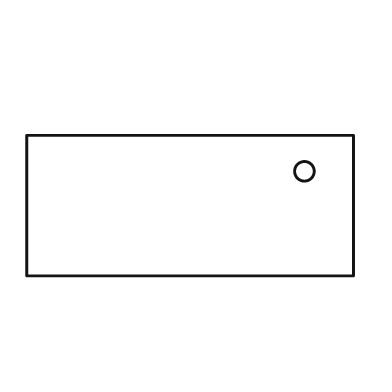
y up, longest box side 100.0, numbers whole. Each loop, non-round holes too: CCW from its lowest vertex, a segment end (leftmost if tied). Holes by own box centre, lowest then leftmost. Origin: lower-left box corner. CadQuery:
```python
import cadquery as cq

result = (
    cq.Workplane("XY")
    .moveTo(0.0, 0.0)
    .lineTo(100.0, 0.0)
    .lineTo(100.0, 43.0)
    .lineTo(0.0, 43.0)
    .close()
    .moveTo(85.0, 32.0)
    .circle(3.0)
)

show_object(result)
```